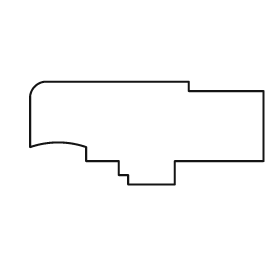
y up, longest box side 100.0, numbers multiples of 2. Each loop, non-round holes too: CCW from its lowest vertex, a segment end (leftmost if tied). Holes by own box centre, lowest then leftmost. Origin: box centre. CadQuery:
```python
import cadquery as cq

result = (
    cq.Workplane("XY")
    .moveTo(-8.0, -22.0)
    .lineTo(12.0, -22.0)
    .lineTo(12.0, -12.0)
    .lineTo(50.0, -12.0)
    .lineTo(50.0, 18.0)
    .lineTo(18.0, 18.0)
    .lineTo(18.0, 22.0)
    .lineTo(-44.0, 22.0)
    .threePointArc((-48.0, 20.0), (-50.0, 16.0))
    .lineTo(-50.0, -6.0)
    .threePointArc((-38.0, -4.0), (-26.0, -6.0))
    .lineTo(-26.0, -12.0)
    .lineTo(-12.0, -12.0)
    .lineTo(-12.0, -18.0)
    .lineTo(-8.0, -18.0)
    .close()
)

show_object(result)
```